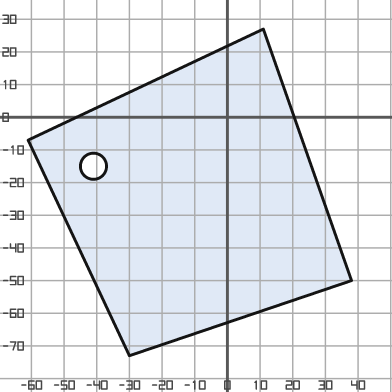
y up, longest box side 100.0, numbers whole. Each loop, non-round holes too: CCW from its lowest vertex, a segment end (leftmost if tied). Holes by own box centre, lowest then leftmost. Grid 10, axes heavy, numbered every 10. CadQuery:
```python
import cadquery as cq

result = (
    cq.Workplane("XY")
    .moveTo(-30.0, -73.0)
    .lineTo(38.0, -50.0)
    .lineTo(11.0, 27.0)
    .lineTo(-61.0, -7.0)
    .close()
    .moveTo(-41.0, -15.0)
    .circle(4.0)
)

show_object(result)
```